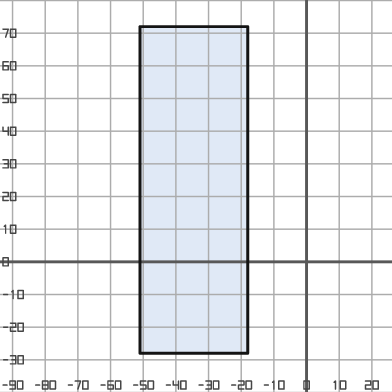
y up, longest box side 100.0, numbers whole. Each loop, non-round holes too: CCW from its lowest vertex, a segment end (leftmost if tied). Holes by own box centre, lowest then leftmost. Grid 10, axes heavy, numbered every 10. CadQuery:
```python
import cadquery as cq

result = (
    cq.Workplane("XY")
    .moveTo(-51.0, -28.0)
    .lineTo(-18.0, -28.0)
    .lineTo(-18.0, 72.0)
    .lineTo(-51.0, 72.0)
    .close()
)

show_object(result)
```